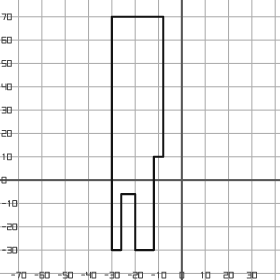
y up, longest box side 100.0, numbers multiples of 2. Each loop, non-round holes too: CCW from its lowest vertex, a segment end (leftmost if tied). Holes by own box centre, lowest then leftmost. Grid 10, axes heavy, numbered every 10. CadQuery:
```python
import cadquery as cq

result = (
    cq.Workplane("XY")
    .moveTo(-30.0, -30.0)
    .lineTo(-26.0, -30.0)
    .lineTo(-26.0, -6.0)
    .lineTo(-20.0, -6.0)
    .lineTo(-20.0, -30.0)
    .lineTo(-12.0, -30.0)
    .lineTo(-12.0, 10.0)
    .lineTo(-8.0, 10.0)
    .lineTo(-8.0, 70.0)
    .lineTo(-30.0, 70.0)
    .close()
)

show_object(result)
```